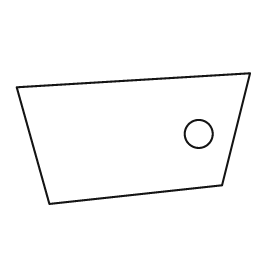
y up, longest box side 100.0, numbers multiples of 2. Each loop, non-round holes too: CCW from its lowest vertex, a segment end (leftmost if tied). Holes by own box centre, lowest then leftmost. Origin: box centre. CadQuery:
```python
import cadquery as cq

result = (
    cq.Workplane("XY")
    .moveTo(-36.0, -28.0)
    .lineTo(38.0, -20.0)
    .lineTo(50.0, 28.0)
    .lineTo(-50.0, 22.0)
    .close()
    .moveTo(28.0, 2.0)
    .circle(6.0)
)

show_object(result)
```